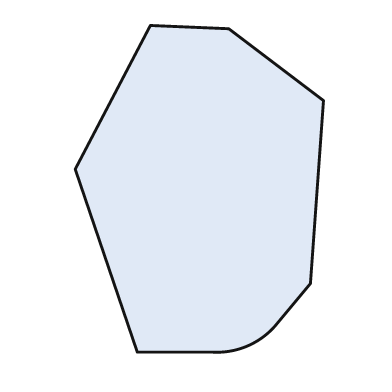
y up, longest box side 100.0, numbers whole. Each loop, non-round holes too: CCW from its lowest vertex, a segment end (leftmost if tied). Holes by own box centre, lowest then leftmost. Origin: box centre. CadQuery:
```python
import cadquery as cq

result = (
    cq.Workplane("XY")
    .moveTo(-19.0, -50.0)
    .lineTo(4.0, -50.0)
    .threePointArc((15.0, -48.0), (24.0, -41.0))
    .lineTo(34.0, -29.0)
    .lineTo(38.0, 27.0)
    .lineTo(9.0, 49.0)
    .lineTo(-15.0, 50.0)
    .lineTo(-38.0, 6.0)
    .close()
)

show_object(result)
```